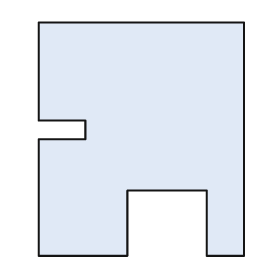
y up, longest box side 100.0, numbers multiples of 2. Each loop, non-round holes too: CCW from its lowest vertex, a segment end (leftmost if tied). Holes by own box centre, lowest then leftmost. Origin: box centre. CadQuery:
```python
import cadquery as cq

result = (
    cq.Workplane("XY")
    .moveTo(-44.0, -50.0)
    .lineTo(-6.0, -50.0)
    .lineTo(-6.0, -22.0)
    .lineTo(28.0, -22.0)
    .lineTo(28.0, -50.0)
    .lineTo(44.0, -50.0)
    .lineTo(44.0, 50.0)
    .lineTo(-44.0, 50.0)
    .lineTo(-44.0, 8.0)
    .lineTo(-24.0, 8.0)
    .lineTo(-24.0, 0.0)
    .lineTo(-44.0, 0.0)
    .close()
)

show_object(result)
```